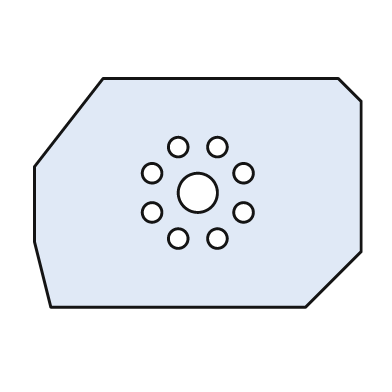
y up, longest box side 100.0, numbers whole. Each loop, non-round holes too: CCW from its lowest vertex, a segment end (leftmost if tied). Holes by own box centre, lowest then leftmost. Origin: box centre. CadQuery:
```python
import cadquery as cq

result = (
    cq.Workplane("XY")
    .moveTo(-45.0, -35.0)
    .lineTo(33.0, -35.0)
    .lineTo(50.0, -18.0)
    .lineTo(50.0, 28.0)
    .lineTo(43.0, 35.0)
    .lineTo(-29.0, 35.0)
    .lineTo(-50.0, 8.0)
    .lineTo(-50.0, -15.0)
    .close()
    .moveTo(-6.0, -14.0)
    .circle(3.0)
    .moveTo(6.0, -14.0)
    .circle(3.0)
    .moveTo(-14.0, -6.0)
    .circle(3.0)
    .moveTo(14.0, -6.0)
    .circle(3.0)
    .moveTo(0.0, 0.0)
    .circle(6.0)
    .moveTo(-14.0, 6.0)
    .circle(3.0)
    .moveTo(14.0, 6.0)
    .circle(3.0)
    .moveTo(-6.0, 14.0)
    .circle(3.0)
    .moveTo(6.0, 14.0)
    .circle(3.0)
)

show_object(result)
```